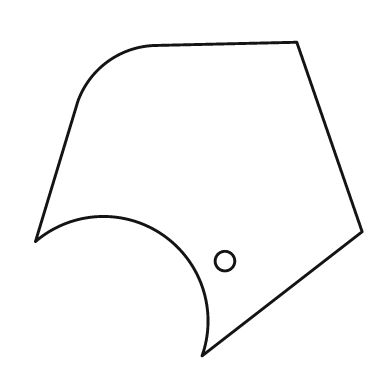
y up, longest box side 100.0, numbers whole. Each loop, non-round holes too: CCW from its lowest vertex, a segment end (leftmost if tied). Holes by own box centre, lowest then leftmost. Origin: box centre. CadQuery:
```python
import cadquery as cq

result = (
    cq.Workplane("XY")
    .moveTo(1.0, -48.0)
    .lineTo(50.0, -10.0)
    .lineTo(30.0, 48.0)
    .lineTo(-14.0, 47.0)
    .threePointArc((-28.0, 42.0), (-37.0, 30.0))
    .lineTo(-50.0, -13.0)
    .threePointArc((-11.0, -11.0), (1.0, -48.0))
    .close()
    .moveTo(8.0, -19.0)
    .circle(3.0)
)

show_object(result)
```